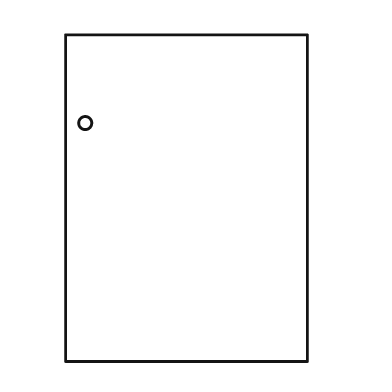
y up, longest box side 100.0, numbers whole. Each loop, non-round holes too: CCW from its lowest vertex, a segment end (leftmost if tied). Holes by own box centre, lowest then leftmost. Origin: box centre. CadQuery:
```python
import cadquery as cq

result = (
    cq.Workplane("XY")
    .moveTo(-37.0, -50.0)
    .lineTo(37.0, -50.0)
    .lineTo(37.0, 50.0)
    .lineTo(-37.0, 50.0)
    .close()
    .moveTo(-31.0, 23.0)
    .circle(2.0)
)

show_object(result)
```